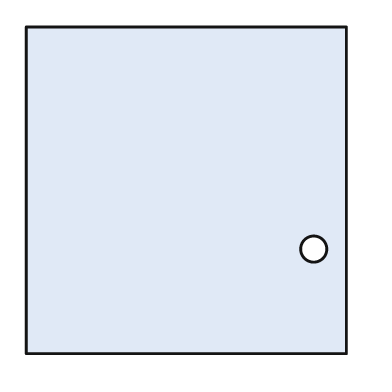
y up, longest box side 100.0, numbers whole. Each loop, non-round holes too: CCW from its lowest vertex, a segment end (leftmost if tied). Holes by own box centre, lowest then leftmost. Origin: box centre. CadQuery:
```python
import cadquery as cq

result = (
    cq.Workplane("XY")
    .moveTo(-49.0, -50.0)
    .lineTo(49.0, -50.0)
    .lineTo(49.0, 50.0)
    .lineTo(-49.0, 50.0)
    .close()
    .moveTo(39.0, -18.0)
    .circle(4.0)
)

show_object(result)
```